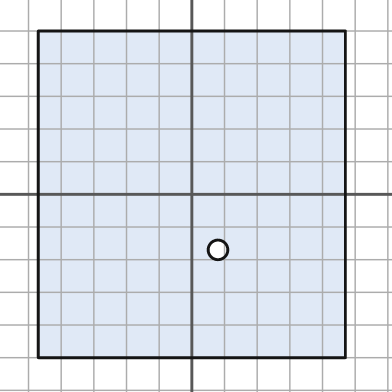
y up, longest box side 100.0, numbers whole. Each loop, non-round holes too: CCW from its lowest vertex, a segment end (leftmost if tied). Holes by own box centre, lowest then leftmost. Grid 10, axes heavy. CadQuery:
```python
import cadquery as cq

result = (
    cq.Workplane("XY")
    .moveTo(-47.0, -50.0)
    .lineTo(47.0, -50.0)
    .lineTo(47.0, 50.0)
    .lineTo(-47.0, 50.0)
    .close()
    .moveTo(8.0, -17.0)
    .circle(3.0)
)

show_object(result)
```